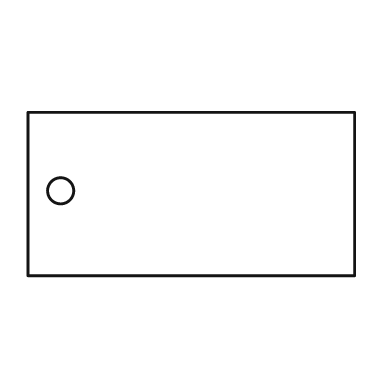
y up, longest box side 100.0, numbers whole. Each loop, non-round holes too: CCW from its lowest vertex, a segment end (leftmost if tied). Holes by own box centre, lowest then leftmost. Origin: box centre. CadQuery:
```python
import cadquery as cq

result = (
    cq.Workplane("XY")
    .moveTo(-50.0, -25.0)
    .lineTo(50.0, -25.0)
    .lineTo(50.0, 25.0)
    .lineTo(-50.0, 25.0)
    .close()
    .moveTo(-40.0, 1.0)
    .circle(4.0)
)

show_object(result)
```